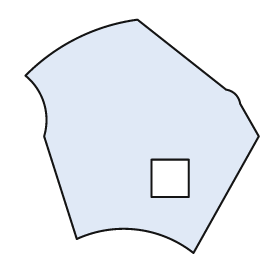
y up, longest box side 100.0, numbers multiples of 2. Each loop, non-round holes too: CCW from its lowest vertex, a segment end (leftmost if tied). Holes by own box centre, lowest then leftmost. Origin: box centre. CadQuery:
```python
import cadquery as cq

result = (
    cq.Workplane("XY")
    .moveTo(22.0, -50.0)
    .lineTo(50.0, 0.0)
    .lineTo(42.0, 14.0)
    .threePointArc((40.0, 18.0), (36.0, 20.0))
    .lineTo(-2.0, 50.0)
    .threePointArc((-28.0, 42.0), (-50.0, 26.0))
    .threePointArc((-42.0, 14.0), (-42.0, 0.0))
    .lineTo(-28.0, -44.0)
    .threePointArc((-2.0, -40.0), (22.0, -50.0))
    .close()
    .moveTo(4.0, -26.0)
    .lineTo(20.0, -26.0)
    .lineTo(20.0, -10.0)
    .lineTo(4.0, -10.0)
    .close()
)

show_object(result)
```